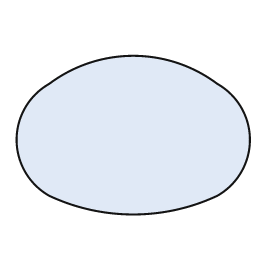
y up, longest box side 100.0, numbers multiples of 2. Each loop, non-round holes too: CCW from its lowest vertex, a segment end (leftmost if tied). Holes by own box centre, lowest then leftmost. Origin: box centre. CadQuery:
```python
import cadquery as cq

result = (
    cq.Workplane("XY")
    .moveTo(-36.0, -26.0)
    .threePointArc((0.0, -34.0), (36.0, -26.0))
    .threePointArc((50.0, -2.0), (36.0, 22.0))
    .threePointArc((0.0, 34.0), (-36.0, 22.0))
    .threePointArc((-50.0, -2.0), (-36.0, -26.0))
    .close()
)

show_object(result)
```